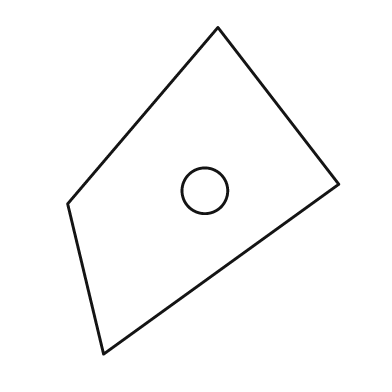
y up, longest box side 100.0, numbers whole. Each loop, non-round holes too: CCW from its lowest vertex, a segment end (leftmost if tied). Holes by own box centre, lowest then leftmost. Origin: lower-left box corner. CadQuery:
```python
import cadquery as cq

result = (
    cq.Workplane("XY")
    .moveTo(11.0, 0.0)
    .lineTo(83.0, 52.0)
    .lineTo(46.0, 100.0)
    .lineTo(0.0, 46.0)
    .close()
    .moveTo(42.0, 50.0)
    .circle(7.0)
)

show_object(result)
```